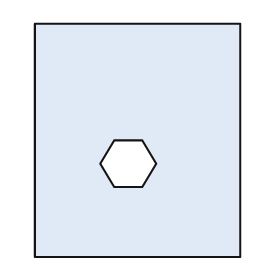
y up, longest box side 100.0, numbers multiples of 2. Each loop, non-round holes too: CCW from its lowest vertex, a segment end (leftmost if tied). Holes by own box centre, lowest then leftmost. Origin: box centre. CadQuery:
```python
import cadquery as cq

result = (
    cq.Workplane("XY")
    .moveTo(-44.0, -50.0)
    .lineTo(44.0, -50.0)
    .lineTo(44.0, 50.0)
    .lineTo(-44.0, 50.0)
    .close()
    .moveTo(-10.0, -20.0)
    .lineTo(2.0, -20.0)
    .lineTo(8.0, -10.0)
    .lineTo(2.0, 0.0)
    .lineTo(-10.0, 0.0)
    .lineTo(-16.0, -10.0)
    .close()
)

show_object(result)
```